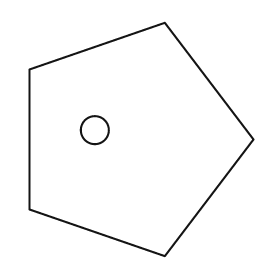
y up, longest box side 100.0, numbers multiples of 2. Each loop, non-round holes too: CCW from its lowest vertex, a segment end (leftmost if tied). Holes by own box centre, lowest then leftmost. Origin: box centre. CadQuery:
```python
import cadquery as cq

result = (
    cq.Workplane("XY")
    .moveTo(10.0, -50.0)
    .lineTo(48.0, 0.0)
    .lineTo(10.0, 50.0)
    .lineTo(-48.0, 30.0)
    .lineTo(-48.0, -30.0)
    .close()
    .moveTo(-20.0, 4.0)
    .circle(6.0)
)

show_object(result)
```